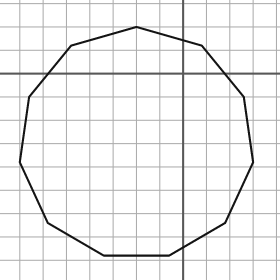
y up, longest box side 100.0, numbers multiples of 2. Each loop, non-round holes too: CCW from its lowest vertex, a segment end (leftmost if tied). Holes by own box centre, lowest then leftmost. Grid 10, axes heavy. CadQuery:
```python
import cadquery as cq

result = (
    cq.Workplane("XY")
    .moveTo(-34.0, -78.0)
    .lineTo(-6.0, -78.0)
    .lineTo(18.0, -64.0)
    .lineTo(30.0, -38.0)
    .lineTo(26.0, -10.0)
    .lineTo(8.0, 12.0)
    .lineTo(-20.0, 20.0)
    .lineTo(-48.0, 12.0)
    .lineTo(-66.0, -10.0)
    .lineTo(-70.0, -38.0)
    .lineTo(-58.0, -64.0)
    .close()
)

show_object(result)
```